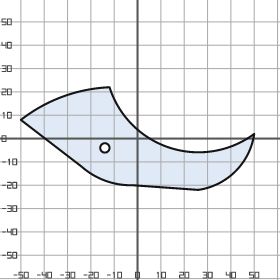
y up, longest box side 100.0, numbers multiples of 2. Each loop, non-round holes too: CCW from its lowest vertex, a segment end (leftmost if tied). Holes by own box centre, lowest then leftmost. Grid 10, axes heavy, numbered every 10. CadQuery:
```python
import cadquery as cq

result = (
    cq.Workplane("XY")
    .moveTo(26.0, -22.0)
    .threePointArc((42.0, -14.0), (50.0, 2.0))
    .threePointArc((14.0, -4.0), (-12.0, 22.0))
    .threePointArc((-32.0, 18.0), (-50.0, 8.0))
    .lineTo(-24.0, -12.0)
    .threePointArc((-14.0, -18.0), (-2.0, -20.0))
    .close()
    .moveTo(-14.0, -4.0)
    .circle(2.0)
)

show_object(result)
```